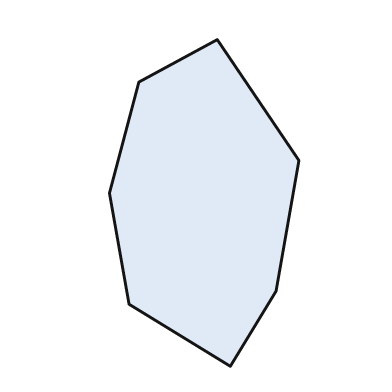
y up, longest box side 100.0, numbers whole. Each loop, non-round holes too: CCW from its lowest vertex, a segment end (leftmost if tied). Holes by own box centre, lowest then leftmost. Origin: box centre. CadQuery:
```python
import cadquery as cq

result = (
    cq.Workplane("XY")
    .moveTo(8.0, -50.0)
    .lineTo(22.0, -27.0)
    .lineTo(29.0, 13.0)
    .lineTo(4.0, 50.0)
    .lineTo(-20.0, 37.0)
    .lineTo(-29.0, 3.0)
    .lineTo(-23.0, -31.0)
    .close()
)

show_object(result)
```